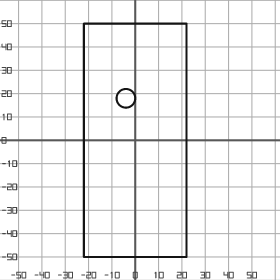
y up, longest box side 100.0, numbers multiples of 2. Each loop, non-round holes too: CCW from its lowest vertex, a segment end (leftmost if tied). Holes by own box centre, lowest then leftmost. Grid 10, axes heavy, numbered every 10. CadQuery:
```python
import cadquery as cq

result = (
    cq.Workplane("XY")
    .moveTo(-22.0, -50.0)
    .lineTo(22.0, -50.0)
    .lineTo(22.0, 50.0)
    .lineTo(-22.0, 50.0)
    .close()
    .moveTo(-4.0, 18.0)
    .circle(4.0)
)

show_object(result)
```